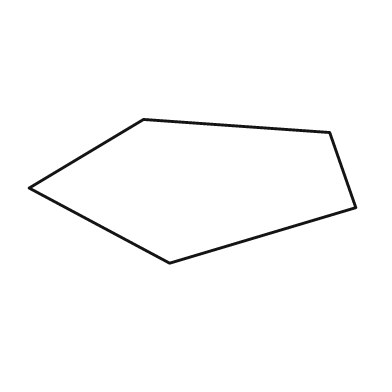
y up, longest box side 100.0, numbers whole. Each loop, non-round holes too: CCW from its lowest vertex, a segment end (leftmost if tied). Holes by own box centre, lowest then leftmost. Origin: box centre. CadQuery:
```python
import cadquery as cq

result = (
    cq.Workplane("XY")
    .moveTo(-7.0, -22.0)
    .lineTo(50.0, -5.0)
    .lineTo(42.0, 18.0)
    .lineTo(-15.0, 22.0)
    .lineTo(-50.0, 1.0)
    .close()
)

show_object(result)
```